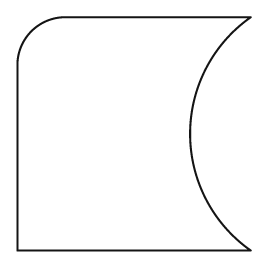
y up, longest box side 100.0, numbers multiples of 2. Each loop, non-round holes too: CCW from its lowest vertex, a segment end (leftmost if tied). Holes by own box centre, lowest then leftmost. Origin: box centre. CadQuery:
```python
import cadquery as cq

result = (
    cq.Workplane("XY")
    .moveTo(-50.0, -50.0)
    .lineTo(50.0, -50.0)
    .threePointArc((24.0, 0.0), (50.0, 50.0))
    .lineTo(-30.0, 50.0)
    .threePointArc((-44.0, 44.0), (-50.0, 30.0))
    .close()
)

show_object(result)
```